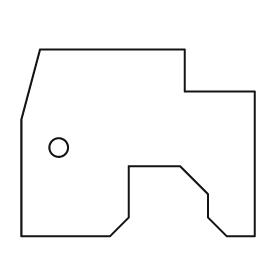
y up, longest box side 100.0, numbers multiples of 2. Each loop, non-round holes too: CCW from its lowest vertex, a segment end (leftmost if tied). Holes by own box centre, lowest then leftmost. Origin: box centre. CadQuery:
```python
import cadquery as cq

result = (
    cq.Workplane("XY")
    .moveTo(-50.0, -40.0)
    .lineTo(-12.0, -40.0)
    .lineTo(-4.0, -32.0)
    .lineTo(-4.0, -10.0)
    .lineTo(18.0, -10.0)
    .lineTo(30.0, -22.0)
    .lineTo(30.0, -32.0)
    .lineTo(38.0, -40.0)
    .lineTo(50.0, -40.0)
    .lineTo(50.0, 22.0)
    .lineTo(20.0, 22.0)
    .lineTo(20.0, 40.0)
    .lineTo(-42.0, 40.0)
    .lineTo(-50.0, 10.0)
    .close()
    .moveTo(-34.0, -2.0)
    .circle(4.0)
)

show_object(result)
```